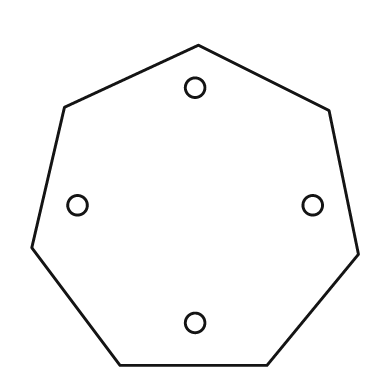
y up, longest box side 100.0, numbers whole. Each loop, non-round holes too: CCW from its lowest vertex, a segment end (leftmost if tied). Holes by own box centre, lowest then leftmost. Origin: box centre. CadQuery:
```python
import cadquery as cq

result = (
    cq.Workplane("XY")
    .moveTo(-23.0, -49.0)
    .lineTo(22.0, -49.0)
    .lineTo(50.0, -15.0)
    .lineTo(41.0, 29.0)
    .lineTo(1.0, 49.0)
    .lineTo(-40.0, 30.0)
    .lineTo(-50.0, -13.0)
    .close()
    .moveTo(0.0, -36.0)
    .circle(3.0)
    .moveTo(-36.0, 0.0)
    .circle(3.0)
    .moveTo(36.0, 0.0)
    .circle(3.0)
    .moveTo(0.0, 36.0)
    .circle(3.0)
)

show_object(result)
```